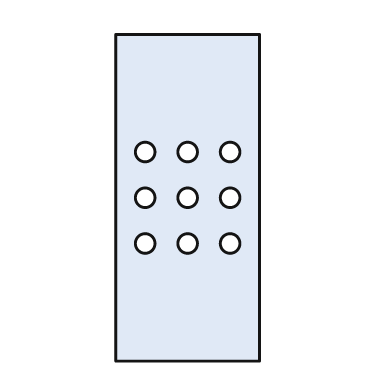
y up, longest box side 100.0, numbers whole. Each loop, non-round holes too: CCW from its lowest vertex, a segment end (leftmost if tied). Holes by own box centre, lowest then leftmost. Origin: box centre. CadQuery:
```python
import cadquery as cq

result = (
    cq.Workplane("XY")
    .moveTo(-22.0, -50.0)
    .lineTo(22.0, -50.0)
    .lineTo(22.0, 50.0)
    .lineTo(-22.0, 50.0)
    .close()
    .moveTo(-13.0, -14.0)
    .circle(3.0)
    .moveTo(0.0, -14.0)
    .circle(3.0)
    .moveTo(13.0, -14.0)
    .circle(3.0)
    .moveTo(-13.0, 0.0)
    .circle(3.0)
    .moveTo(0.0, 0.0)
    .circle(3.0)
    .moveTo(13.0, 0.0)
    .circle(3.0)
    .moveTo(-13.0, 14.0)
    .circle(3.0)
    .moveTo(0.0, 14.0)
    .circle(3.0)
    .moveTo(13.0, 14.0)
    .circle(3.0)
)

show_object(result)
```